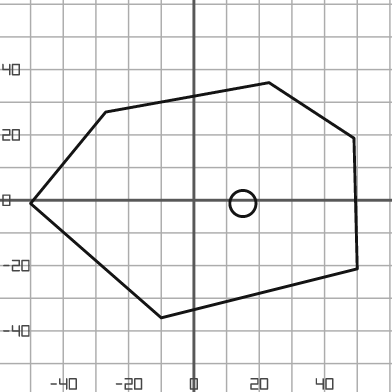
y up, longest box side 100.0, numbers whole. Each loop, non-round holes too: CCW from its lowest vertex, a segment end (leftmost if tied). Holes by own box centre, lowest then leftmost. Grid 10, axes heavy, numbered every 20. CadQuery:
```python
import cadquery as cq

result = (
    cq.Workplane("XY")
    .moveTo(-10.0, -36.0)
    .lineTo(50.0, -21.0)
    .lineTo(49.0, 19.0)
    .lineTo(23.0, 36.0)
    .lineTo(-27.0, 27.0)
    .lineTo(-50.0, -1.0)
    .close()
    .moveTo(15.0, -1.0)
    .circle(4.0)
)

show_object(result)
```